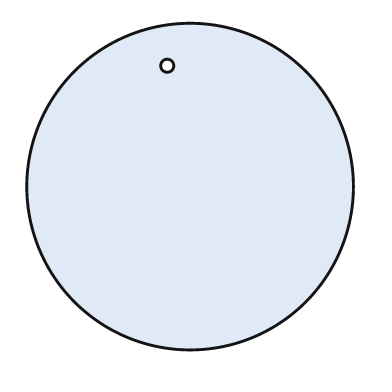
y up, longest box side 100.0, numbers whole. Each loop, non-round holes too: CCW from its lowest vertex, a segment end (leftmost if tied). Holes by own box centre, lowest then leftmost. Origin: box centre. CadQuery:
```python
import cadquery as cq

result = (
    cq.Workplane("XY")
    .moveTo(0.0, 0.0)
    .circle(50.0)
    .moveTo(-7.0, 37.0)
    .circle(2.0)
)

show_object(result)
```